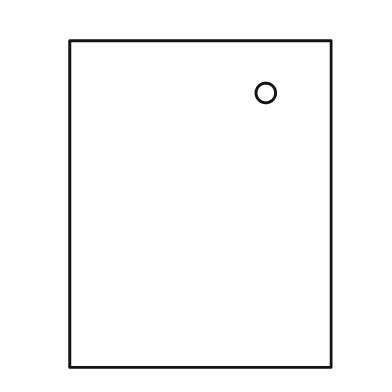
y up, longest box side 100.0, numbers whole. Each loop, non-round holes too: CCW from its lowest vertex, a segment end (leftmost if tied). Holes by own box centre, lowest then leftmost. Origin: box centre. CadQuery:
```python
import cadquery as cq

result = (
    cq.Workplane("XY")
    .moveTo(-40.0, -50.0)
    .lineTo(40.0, -50.0)
    .lineTo(40.0, 50.0)
    .lineTo(-40.0, 50.0)
    .close()
    .moveTo(20.0, 34.0)
    .circle(3.0)
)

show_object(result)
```